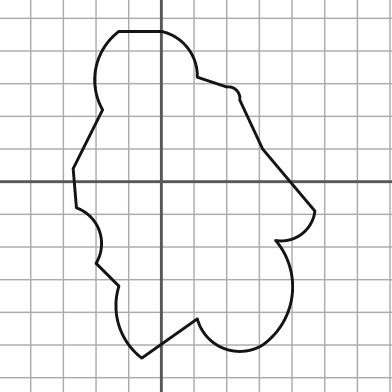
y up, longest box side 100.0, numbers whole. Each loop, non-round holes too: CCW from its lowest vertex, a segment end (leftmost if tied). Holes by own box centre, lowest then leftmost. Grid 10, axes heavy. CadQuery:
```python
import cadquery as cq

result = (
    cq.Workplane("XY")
    .moveTo(-6.0, -54.0)
    .lineTo(11.0, -42.0)
    .threePointArc((19.0, -51.0), (31.0, -50.0))
    .threePointArc((40.0, -35.0), (35.0, -18.0))
    .threePointArc((43.0, -16.0), (47.0, -9.0))
    .lineTo(31.0, 10.0)
    .lineTo(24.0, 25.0)
    .threePointArc((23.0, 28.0), (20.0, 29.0))
    .lineTo(11.0, 32.0)
    .threePointArc((8.0, 41.0), (0.0, 46.0))
    .lineTo(-13.0, 46.0)
    .threePointArc((-20.0, 35.0), (-18.0, 22.0))
    .lineTo(-27.0, 4.0)
    .lineTo(-26.0, -8.0)
    .threePointArc((-19.0, -15.0), (-20.0, -25.0))
    .lineTo(-13.0, -32.0)
    .threePointArc((-13.0, -44.0), (-6.0, -54.0))
    .close()
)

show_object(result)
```